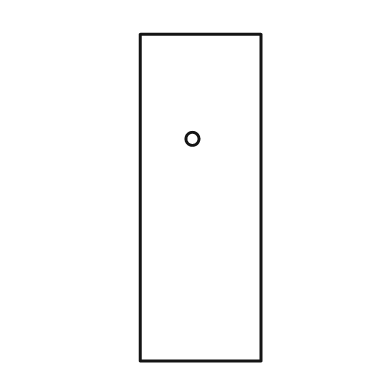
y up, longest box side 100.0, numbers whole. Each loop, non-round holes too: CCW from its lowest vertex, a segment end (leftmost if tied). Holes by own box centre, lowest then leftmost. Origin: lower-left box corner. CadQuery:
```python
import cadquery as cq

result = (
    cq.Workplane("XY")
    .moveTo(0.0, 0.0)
    .lineTo(37.0, 0.0)
    .lineTo(37.0, 100.0)
    .lineTo(0.0, 100.0)
    .close()
    .moveTo(16.0, 68.0)
    .circle(2.0)
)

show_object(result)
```